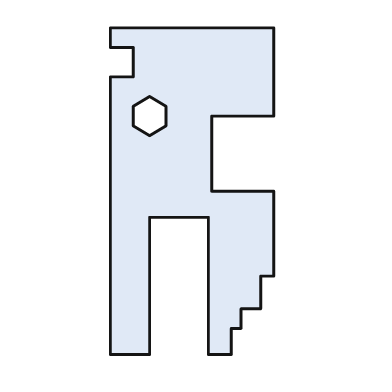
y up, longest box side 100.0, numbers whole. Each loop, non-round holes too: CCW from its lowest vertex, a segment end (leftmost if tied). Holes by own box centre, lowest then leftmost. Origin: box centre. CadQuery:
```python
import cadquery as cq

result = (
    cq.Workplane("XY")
    .moveTo(-25.0, -50.0)
    .lineTo(-13.0, -50.0)
    .lineTo(-13.0, -8.0)
    .lineTo(5.0, -8.0)
    .lineTo(5.0, -50.0)
    .lineTo(12.0, -50.0)
    .lineTo(12.0, -42.0)
    .lineTo(15.0, -42.0)
    .lineTo(15.0, -36.0)
    .lineTo(21.0, -36.0)
    .lineTo(21.0, -26.0)
    .lineTo(25.0, -26.0)
    .lineTo(25.0, 0.0)
    .lineTo(6.0, 0.0)
    .lineTo(6.0, 23.0)
    .lineTo(25.0, 23.0)
    .lineTo(25.0, 50.0)
    .lineTo(-25.0, 50.0)
    .lineTo(-25.0, 44.0)
    .lineTo(-18.0, 44.0)
    .lineTo(-18.0, 35.0)
    .lineTo(-25.0, 35.0)
    .close()
    .moveTo(-13.0, 17.0)
    .lineTo(-8.0, 20.0)
    .lineTo(-8.0, 26.0)
    .lineTo(-13.0, 29.0)
    .lineTo(-18.0, 26.0)
    .lineTo(-18.0, 20.0)
    .close()
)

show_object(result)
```